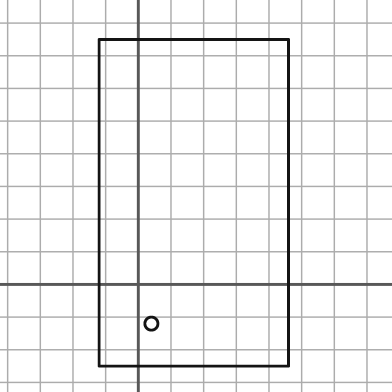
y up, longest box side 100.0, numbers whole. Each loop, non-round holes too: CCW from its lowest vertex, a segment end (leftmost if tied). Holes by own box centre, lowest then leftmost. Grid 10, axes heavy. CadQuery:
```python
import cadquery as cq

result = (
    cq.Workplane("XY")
    .moveTo(-12.0, -25.0)
    .lineTo(46.0, -25.0)
    .lineTo(46.0, 75.0)
    .lineTo(-12.0, 75.0)
    .close()
    .moveTo(4.0, -12.0)
    .circle(2.0)
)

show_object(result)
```